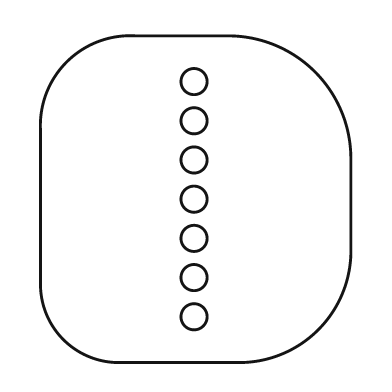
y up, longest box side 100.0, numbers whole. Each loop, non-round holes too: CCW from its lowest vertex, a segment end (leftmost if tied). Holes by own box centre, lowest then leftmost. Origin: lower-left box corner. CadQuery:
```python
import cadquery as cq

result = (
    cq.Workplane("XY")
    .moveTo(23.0, 0.0)
    .lineTo(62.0, 0.0)
    .threePointArc((85.0, 10.0), (95.0, 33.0))
    .lineTo(95.0, 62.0)
    .threePointArc((84.0, 89.0), (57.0, 100.0))
    .lineTo(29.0, 100.0)
    .threePointArc((8.0, 92.0), (0.0, 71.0))
    .lineTo(0.0, 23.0)
    .threePointArc((7.0, 7.0), (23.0, 0.0))
    .close()
    .moveTo(47.0, 14.0)
    .circle(4.0)
    .moveTo(47.0, 26.0)
    .circle(4.0)
    .moveTo(47.0, 38.0)
    .circle(4.0)
    .moveTo(47.0, 50.0)
    .circle(4.0)
    .moveTo(47.0, 62.0)
    .circle(4.0)
    .moveTo(47.0, 74.0)
    .circle(4.0)
    .moveTo(47.0, 86.0)
    .circle(4.0)
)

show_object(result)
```